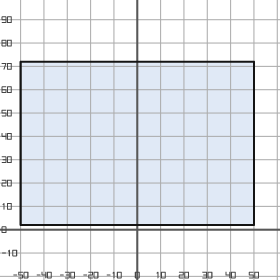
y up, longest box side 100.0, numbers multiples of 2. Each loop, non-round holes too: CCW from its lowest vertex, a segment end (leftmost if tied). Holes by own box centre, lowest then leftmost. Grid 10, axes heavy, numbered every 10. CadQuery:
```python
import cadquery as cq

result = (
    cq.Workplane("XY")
    .moveTo(-50.0, 2.0)
    .lineTo(50.0, 2.0)
    .lineTo(50.0, 72.0)
    .lineTo(-50.0, 72.0)
    .close()
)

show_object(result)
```